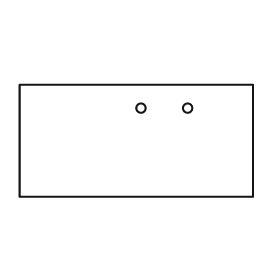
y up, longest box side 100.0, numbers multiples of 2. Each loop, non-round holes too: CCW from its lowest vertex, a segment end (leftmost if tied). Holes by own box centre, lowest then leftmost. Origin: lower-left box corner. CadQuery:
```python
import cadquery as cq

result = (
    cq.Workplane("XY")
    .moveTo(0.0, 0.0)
    .lineTo(100.0, 0.0)
    .lineTo(100.0, 48.0)
    .lineTo(0.0, 48.0)
    .close()
    .moveTo(52.0, 38.0)
    .circle(2.0)
    .moveTo(72.0, 38.0)
    .circle(2.0)
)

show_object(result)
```